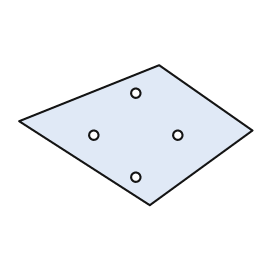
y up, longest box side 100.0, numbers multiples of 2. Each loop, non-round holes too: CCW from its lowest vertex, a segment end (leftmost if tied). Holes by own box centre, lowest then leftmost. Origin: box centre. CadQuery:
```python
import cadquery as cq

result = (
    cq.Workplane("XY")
    .moveTo(6.0, -30.0)
    .lineTo(50.0, 2.0)
    .lineTo(10.0, 30.0)
    .lineTo(-50.0, 6.0)
    .close()
    .moveTo(0.0, -18.0)
    .circle(2.0)
    .moveTo(-18.0, 0.0)
    .circle(2.0)
    .moveTo(18.0, 0.0)
    .circle(2.0)
    .moveTo(0.0, 18.0)
    .circle(2.0)
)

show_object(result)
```